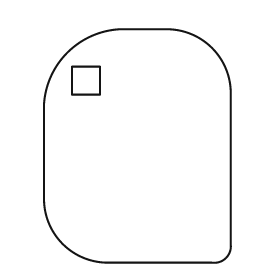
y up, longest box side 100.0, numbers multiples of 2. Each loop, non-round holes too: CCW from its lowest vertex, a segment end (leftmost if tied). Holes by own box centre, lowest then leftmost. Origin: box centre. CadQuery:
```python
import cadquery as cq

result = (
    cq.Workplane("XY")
    .moveTo(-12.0, -50.0)
    .lineTo(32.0, -50.0)
    .threePointArc((38.0, -48.0), (40.0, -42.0))
    .lineTo(40.0, 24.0)
    .threePointArc((32.0, 42.0), (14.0, 50.0))
    .lineTo(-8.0, 50.0)
    .threePointArc((-30.0, 40.0), (-40.0, 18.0))
    .lineTo(-40.0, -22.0)
    .threePointArc((-32.0, -42.0), (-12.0, -50.0))
    .close()
    .moveTo(-28.0, 22.0)
    .lineTo(-16.0, 22.0)
    .lineTo(-16.0, 34.0)
    .lineTo(-28.0, 34.0)
    .close()
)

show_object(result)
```